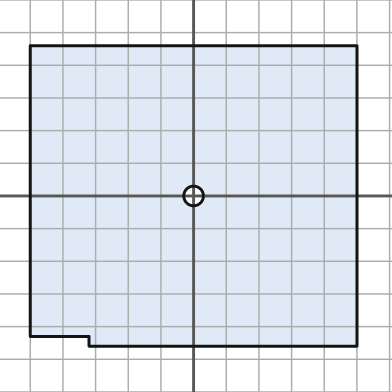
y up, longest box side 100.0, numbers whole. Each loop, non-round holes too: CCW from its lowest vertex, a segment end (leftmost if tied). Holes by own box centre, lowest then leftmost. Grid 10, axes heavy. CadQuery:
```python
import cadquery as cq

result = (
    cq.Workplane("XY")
    .moveTo(-32.0, -46.0)
    .lineTo(50.0, -46.0)
    .lineTo(50.0, 46.0)
    .lineTo(-50.0, 46.0)
    .lineTo(-50.0, -43.0)
    .lineTo(-32.0, -43.0)
    .close()
    .moveTo(0.0, 0.0)
    .circle(3.0)
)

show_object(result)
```